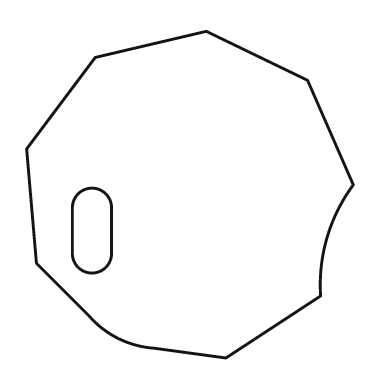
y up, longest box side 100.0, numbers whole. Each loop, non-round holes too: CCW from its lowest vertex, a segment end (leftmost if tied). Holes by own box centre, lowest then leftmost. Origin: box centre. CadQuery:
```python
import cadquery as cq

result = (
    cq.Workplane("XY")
    .moveTo(11.0, -50.0)
    .lineTo(40.0, -31.0)
    .threePointArc((42.0, -13.0), (50.0, 3.0))
    .lineTo(36.0, 35.0)
    .lineTo(5.0, 50.0)
    .lineTo(-29.0, 42.0)
    .lineTo(-50.0, 14.0)
    .lineTo(-47.0, -21.0)
    .lineTo(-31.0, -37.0)
    .threePointArc((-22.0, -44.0), (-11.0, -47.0))
    .close()
    .moveTo(-36.0, -18.0)
    .threePointArc((-30.0, -24.0), (-24.0, -18.0))
    .lineTo(-24.0, -4.0)
    .threePointArc((-30.0, 2.0), (-36.0, -4.0))
    .close()
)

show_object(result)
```